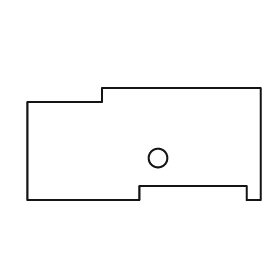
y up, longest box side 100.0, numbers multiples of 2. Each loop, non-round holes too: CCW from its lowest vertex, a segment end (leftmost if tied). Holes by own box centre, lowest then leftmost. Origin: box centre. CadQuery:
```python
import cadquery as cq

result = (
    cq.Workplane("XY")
    .moveTo(-50.0, -24.0)
    .lineTo(-2.0, -24.0)
    .lineTo(-2.0, -18.0)
    .lineTo(44.0, -18.0)
    .lineTo(44.0, -24.0)
    .lineTo(50.0, -24.0)
    .lineTo(50.0, 24.0)
    .lineTo(-18.0, 24.0)
    .lineTo(-18.0, 18.0)
    .lineTo(-50.0, 18.0)
    .close()
    .moveTo(6.0, -6.0)
    .circle(4.0)
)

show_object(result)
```